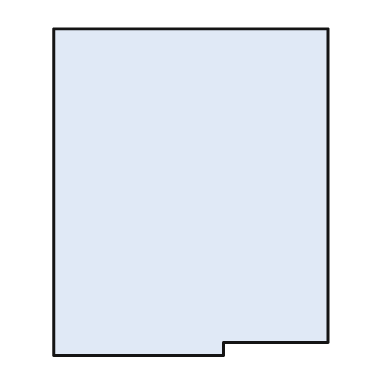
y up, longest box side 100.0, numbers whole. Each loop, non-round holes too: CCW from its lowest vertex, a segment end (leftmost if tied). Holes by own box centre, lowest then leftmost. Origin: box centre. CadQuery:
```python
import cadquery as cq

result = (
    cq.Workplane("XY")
    .moveTo(-42.0, -50.0)
    .lineTo(10.0, -50.0)
    .lineTo(10.0, -46.0)
    .lineTo(42.0, -46.0)
    .lineTo(42.0, 50.0)
    .lineTo(-42.0, 50.0)
    .close()
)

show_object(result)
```